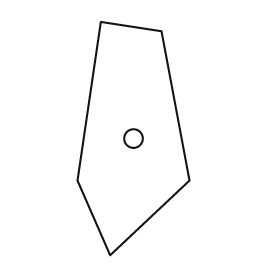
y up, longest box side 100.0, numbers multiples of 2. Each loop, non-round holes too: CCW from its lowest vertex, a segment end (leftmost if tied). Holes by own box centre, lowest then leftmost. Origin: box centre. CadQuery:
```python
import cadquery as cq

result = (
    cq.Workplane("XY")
    .moveTo(-10.0, -50.0)
    .lineTo(24.0, -18.0)
    .lineTo(12.0, 46.0)
    .lineTo(-14.0, 50.0)
    .lineTo(-24.0, -18.0)
    .close()
    .moveTo(0.0, 0.0)
    .circle(4.0)
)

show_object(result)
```